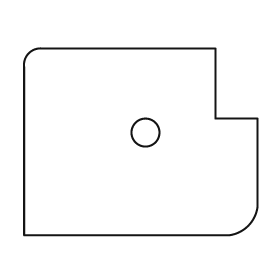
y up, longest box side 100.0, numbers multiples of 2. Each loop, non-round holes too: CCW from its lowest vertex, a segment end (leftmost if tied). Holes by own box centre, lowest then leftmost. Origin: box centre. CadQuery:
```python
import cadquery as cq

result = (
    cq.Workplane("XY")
    .moveTo(-50.0, -40.0)
    .lineTo(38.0, -40.0)
    .threePointArc((46.0, -36.0), (50.0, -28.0))
    .lineTo(50.0, 10.0)
    .lineTo(32.0, 10.0)
    .lineTo(32.0, 40.0)
    .lineTo(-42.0, 40.0)
    .threePointArc((-48.0, 38.0), (-50.0, 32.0))
    .close()
    .moveTo(2.0, 4.0)
    .circle(6.0)
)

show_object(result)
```